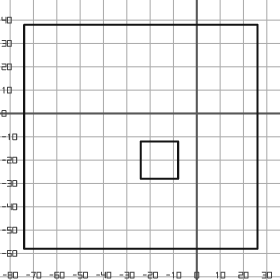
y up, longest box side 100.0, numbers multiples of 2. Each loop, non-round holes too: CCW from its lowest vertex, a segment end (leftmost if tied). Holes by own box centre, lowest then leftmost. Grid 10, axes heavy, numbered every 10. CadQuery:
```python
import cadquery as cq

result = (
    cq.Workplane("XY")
    .moveTo(-74.0, -58.0)
    .lineTo(26.0, -58.0)
    .lineTo(26.0, 38.0)
    .lineTo(-74.0, 38.0)
    .close()
    .moveTo(-24.0, -28.0)
    .lineTo(-8.0, -28.0)
    .lineTo(-8.0, -12.0)
    .lineTo(-24.0, -12.0)
    .close()
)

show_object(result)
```